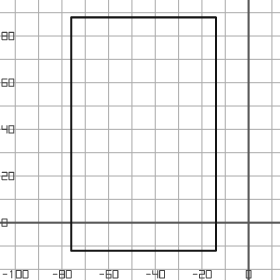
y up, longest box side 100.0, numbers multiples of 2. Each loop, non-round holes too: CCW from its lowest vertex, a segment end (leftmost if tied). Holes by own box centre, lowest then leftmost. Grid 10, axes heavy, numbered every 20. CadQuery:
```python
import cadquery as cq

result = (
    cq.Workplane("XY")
    .moveTo(-76.0, -12.0)
    .lineTo(-14.0, -12.0)
    .lineTo(-14.0, 88.0)
    .lineTo(-76.0, 88.0)
    .close()
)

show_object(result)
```